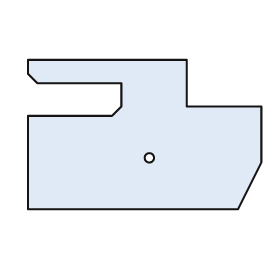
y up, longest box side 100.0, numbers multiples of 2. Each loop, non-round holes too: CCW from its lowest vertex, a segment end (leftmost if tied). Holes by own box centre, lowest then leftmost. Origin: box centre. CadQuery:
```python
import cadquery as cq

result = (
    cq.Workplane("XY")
    .moveTo(-50.0, -32.0)
    .lineTo(40.0, -32.0)
    .lineTo(50.0, -12.0)
    .lineTo(50.0, 12.0)
    .lineTo(18.0, 12.0)
    .lineTo(18.0, 32.0)
    .lineTo(-50.0, 32.0)
    .lineTo(-50.0, 26.0)
    .lineTo(-46.0, 22.0)
    .lineTo(-10.0, 22.0)
    .lineTo(-10.0, 12.0)
    .lineTo(-14.0, 8.0)
    .lineTo(-50.0, 8.0)
    .close()
    .moveTo(2.0, -10.0)
    .circle(2.0)
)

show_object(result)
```